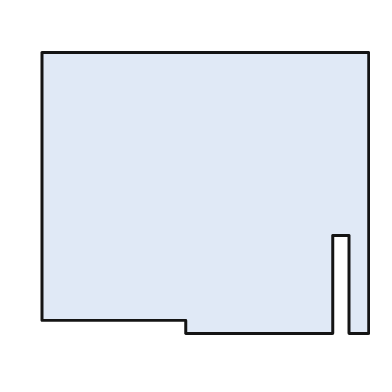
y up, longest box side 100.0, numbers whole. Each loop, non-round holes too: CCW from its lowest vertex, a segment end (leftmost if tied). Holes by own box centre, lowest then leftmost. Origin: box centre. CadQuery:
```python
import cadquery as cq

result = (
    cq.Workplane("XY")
    .moveTo(-6.0, -43.0)
    .lineTo(39.0, -43.0)
    .lineTo(39.0, -13.0)
    .lineTo(44.0, -13.0)
    .lineTo(44.0, -43.0)
    .lineTo(50.0, -43.0)
    .lineTo(50.0, 43.0)
    .lineTo(-50.0, 43.0)
    .lineTo(-50.0, -39.0)
    .lineTo(-6.0, -39.0)
    .close()
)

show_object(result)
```